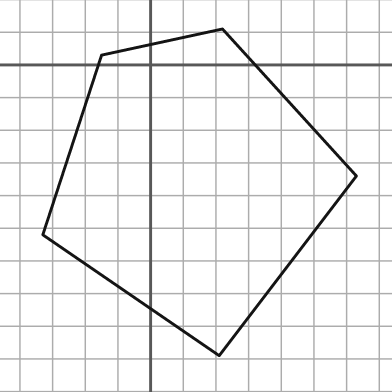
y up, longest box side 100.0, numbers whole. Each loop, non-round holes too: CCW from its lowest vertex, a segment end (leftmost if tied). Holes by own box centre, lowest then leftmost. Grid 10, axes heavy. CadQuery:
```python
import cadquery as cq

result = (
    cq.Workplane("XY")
    .moveTo(21.0, -89.0)
    .lineTo(63.0, -34.0)
    .lineTo(22.0, 11.0)
    .lineTo(-15.0, 3.0)
    .lineTo(-33.0, -52.0)
    .close()
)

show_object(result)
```